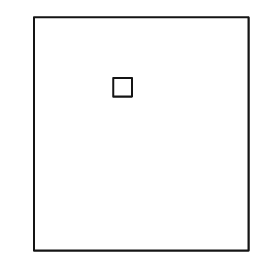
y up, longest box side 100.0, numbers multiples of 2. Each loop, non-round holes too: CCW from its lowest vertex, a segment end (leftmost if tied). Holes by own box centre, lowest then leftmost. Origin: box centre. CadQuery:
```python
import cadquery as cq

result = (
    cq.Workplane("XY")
    .moveTo(-46.0, -50.0)
    .lineTo(46.0, -50.0)
    .lineTo(46.0, 50.0)
    .lineTo(-46.0, 50.0)
    .close()
    .moveTo(-12.0, 16.0)
    .lineTo(-4.0, 16.0)
    .lineTo(-4.0, 24.0)
    .lineTo(-12.0, 24.0)
    .close()
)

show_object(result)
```